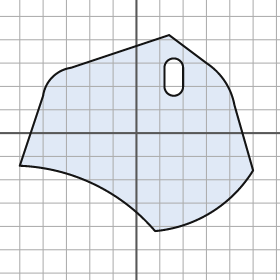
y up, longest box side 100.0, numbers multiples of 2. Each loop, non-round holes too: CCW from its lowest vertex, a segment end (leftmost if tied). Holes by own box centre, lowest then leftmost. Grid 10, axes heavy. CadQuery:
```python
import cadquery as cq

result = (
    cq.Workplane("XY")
    .moveTo(8.0, -42.0)
    .threePointArc((32.0, -34.0), (50.0, -16.0))
    .lineTo(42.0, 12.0)
    .threePointArc((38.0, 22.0), (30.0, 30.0))
    .lineTo(14.0, 42.0)
    .lineTo(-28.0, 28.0)
    .threePointArc((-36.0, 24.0), (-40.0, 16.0))
    .lineTo(-50.0, -14.0)
    .threePointArc((-18.0, -22.0), (8.0, -42.0))
    .close()
    .moveTo(12.0, 20.0)
    .threePointArc((16.0, 16.0), (20.0, 20.0))
    .lineTo(20.0, 28.0)
    .threePointArc((16.0, 32.0), (12.0, 28.0))
    .close()
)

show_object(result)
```